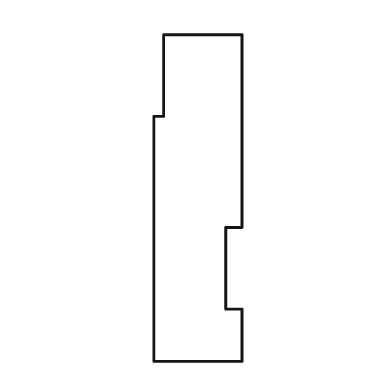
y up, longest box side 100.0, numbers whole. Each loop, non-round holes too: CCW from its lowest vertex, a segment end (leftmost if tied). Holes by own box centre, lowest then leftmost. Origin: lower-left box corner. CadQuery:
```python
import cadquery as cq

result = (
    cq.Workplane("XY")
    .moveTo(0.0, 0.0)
    .lineTo(27.0, 0.0)
    .lineTo(27.0, 16.0)
    .lineTo(22.0, 16.0)
    .lineTo(22.0, 41.0)
    .lineTo(27.0, 41.0)
    .lineTo(27.0, 100.0)
    .lineTo(3.0, 100.0)
    .lineTo(3.0, 75.0)
    .lineTo(0.0, 75.0)
    .close()
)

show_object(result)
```